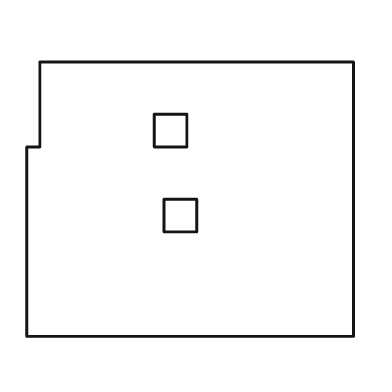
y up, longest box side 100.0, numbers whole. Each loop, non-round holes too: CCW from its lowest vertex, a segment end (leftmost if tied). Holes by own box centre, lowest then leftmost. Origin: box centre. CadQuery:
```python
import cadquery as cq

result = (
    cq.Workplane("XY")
    .moveTo(-50.0, -42.0)
    .lineTo(50.0, -42.0)
    .lineTo(50.0, 42.0)
    .lineTo(-46.0, 42.0)
    .lineTo(-46.0, 16.0)
    .lineTo(-50.0, 16.0)
    .close()
    .moveTo(-8.0, -10.0)
    .lineTo(2.0, -10.0)
    .lineTo(2.0, 0.0)
    .lineTo(-8.0, 0.0)
    .close()
    .moveTo(-11.0, 16.0)
    .lineTo(-1.0, 16.0)
    .lineTo(-1.0, 26.0)
    .lineTo(-11.0, 26.0)
    .close()
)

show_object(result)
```